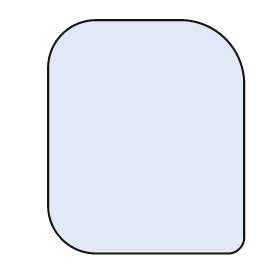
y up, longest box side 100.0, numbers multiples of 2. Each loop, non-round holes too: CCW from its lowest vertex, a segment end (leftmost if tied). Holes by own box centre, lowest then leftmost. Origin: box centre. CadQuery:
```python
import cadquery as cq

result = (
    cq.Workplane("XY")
    .moveTo(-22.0, -50.0)
    .lineTo(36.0, -50.0)
    .threePointArc((40.0, -48.0), (42.0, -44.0))
    .lineTo(42.0, 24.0)
    .threePointArc((34.0, 42.0), (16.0, 50.0))
    .lineTo(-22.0, 50.0)
    .threePointArc((-36.0, 44.0), (-42.0, 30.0))
    .lineTo(-42.0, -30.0)
    .threePointArc((-36.0, -44.0), (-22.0, -50.0))
    .close()
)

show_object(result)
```